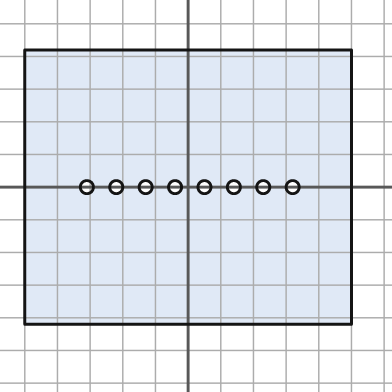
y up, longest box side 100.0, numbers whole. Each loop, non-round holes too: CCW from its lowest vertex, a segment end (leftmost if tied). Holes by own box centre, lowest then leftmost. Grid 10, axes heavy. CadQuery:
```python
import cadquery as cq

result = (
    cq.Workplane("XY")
    .moveTo(-50.0, -42.0)
    .lineTo(50.0, -42.0)
    .lineTo(50.0, 42.0)
    .lineTo(-50.0, 42.0)
    .close()
    .moveTo(-31.0, 0.0)
    .circle(2.0)
    .moveTo(-22.0, 0.0)
    .circle(2.0)
    .moveTo(-13.0, 0.0)
    .circle(2.0)
    .moveTo(-4.0, 0.0)
    .circle(2.0)
    .moveTo(5.0, 0.0)
    .circle(2.0)
    .moveTo(14.0, 0.0)
    .circle(2.0)
    .moveTo(23.0, 0.0)
    .circle(2.0)
    .moveTo(32.0, 0.0)
    .circle(2.0)
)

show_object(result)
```